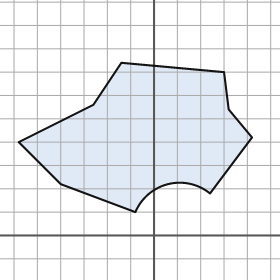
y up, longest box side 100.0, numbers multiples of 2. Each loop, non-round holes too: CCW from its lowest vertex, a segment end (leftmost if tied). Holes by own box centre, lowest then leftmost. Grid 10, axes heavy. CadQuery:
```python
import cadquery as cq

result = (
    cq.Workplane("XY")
    .moveTo(-8.0, 10.0)
    .threePointArc((6.0, 22.0), (24.0, 18.0))
    .lineTo(42.0, 42.0)
    .lineTo(32.0, 54.0)
    .lineTo(30.0, 70.0)
    .lineTo(-14.0, 74.0)
    .lineTo(-26.0, 56.0)
    .lineTo(-58.0, 40.0)
    .lineTo(-40.0, 22.0)
    .close()
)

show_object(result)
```